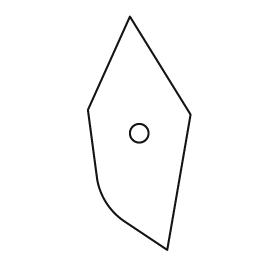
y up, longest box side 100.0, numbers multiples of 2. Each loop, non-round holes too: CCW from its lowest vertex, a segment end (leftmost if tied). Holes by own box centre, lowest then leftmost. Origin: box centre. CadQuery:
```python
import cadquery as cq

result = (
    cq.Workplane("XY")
    .moveTo(12.0, -50.0)
    .lineTo(22.0, 8.0)
    .lineTo(-4.0, 50.0)
    .lineTo(-22.0, 10.0)
    .lineTo(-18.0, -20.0)
    .threePointArc((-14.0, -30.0), (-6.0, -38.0))
    .close()
    .moveTo(0.0, 0.0)
    .circle(4.0)
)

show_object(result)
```